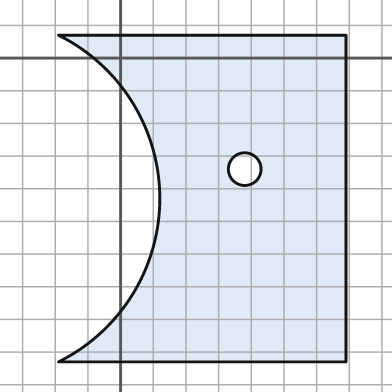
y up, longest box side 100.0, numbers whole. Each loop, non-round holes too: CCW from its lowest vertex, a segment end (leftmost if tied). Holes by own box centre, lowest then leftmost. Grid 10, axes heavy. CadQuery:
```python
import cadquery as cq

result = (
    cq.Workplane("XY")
    .moveTo(-19.0, -93.0)
    .lineTo(69.0, -93.0)
    .lineTo(69.0, 7.0)
    .lineTo(-19.0, 7.0)
    .threePointArc((12.0, -43.0), (-19.0, -93.0))
    .close()
    .moveTo(38.0, -34.0)
    .circle(5.0)
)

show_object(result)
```